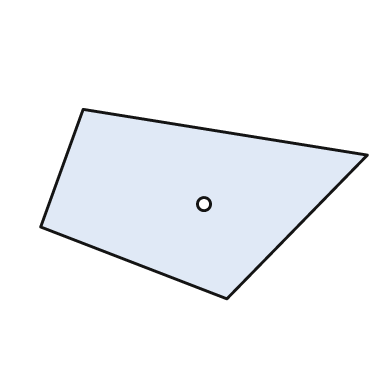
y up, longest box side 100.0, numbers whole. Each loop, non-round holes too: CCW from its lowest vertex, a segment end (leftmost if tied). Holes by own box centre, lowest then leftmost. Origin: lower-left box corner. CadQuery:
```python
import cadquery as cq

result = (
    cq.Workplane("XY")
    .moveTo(57.0, 0.0)
    .lineTo(100.0, 44.0)
    .lineTo(13.0, 58.0)
    .lineTo(0.0, 22.0)
    .close()
    .moveTo(50.0, 29.0)
    .circle(2.0)
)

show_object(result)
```